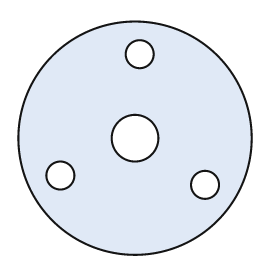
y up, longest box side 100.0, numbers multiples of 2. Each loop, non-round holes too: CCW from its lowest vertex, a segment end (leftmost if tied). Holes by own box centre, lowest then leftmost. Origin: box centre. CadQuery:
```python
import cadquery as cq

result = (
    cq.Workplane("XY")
    .moveTo(0.0, 0.0)
    .circle(50.0)
    .moveTo(30.0, -20.0)
    .circle(6.0)
    .moveTo(-32.0, -16.0)
    .circle(6.0)
    .moveTo(0.0, 0.0)
    .circle(10.0)
    .moveTo(2.0, 36.0)
    .circle(6.0)
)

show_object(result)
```